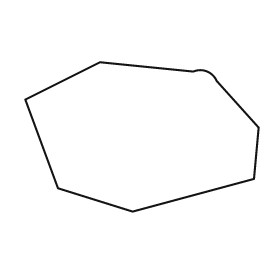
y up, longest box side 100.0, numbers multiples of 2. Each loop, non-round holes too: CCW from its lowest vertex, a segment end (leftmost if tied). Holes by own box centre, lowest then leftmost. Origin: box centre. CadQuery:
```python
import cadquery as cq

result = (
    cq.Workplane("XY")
    .moveTo(-4.0, -32.0)
    .lineTo(48.0, -18.0)
    .lineTo(50.0, 4.0)
    .lineTo(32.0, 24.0)
    .threePointArc((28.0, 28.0), (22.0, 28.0))
    .lineTo(-18.0, 32.0)
    .lineTo(-50.0, 16.0)
    .lineTo(-36.0, -22.0)
    .close()
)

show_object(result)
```